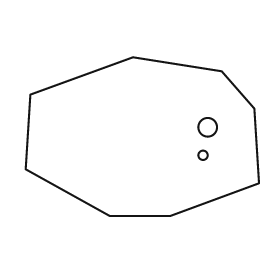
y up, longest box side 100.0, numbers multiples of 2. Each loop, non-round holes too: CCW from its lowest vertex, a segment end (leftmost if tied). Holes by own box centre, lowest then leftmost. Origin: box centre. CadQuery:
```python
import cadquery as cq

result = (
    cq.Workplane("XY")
    .moveTo(-14.0, -34.0)
    .lineTo(12.0, -34.0)
    .lineTo(50.0, -20.0)
    .lineTo(48.0, 12.0)
    .lineTo(34.0, 28.0)
    .lineTo(-4.0, 34.0)
    .lineTo(-48.0, 18.0)
    .lineTo(-50.0, -14.0)
    .close()
    .moveTo(26.0, -8.0)
    .circle(2.0)
    .moveTo(28.0, 4.0)
    .circle(4.0)
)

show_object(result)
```